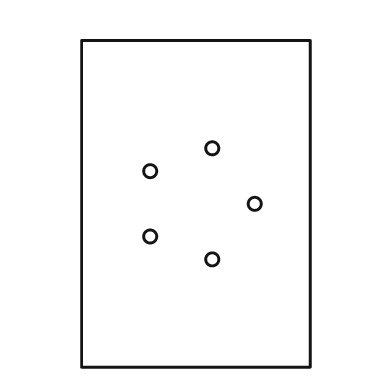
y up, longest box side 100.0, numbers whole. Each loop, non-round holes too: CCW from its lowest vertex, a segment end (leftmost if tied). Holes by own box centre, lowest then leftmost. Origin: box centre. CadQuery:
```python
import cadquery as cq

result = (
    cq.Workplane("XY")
    .moveTo(-35.0, -50.0)
    .lineTo(35.0, -50.0)
    .lineTo(35.0, 50.0)
    .lineTo(-35.0, 50.0)
    .close()
    .moveTo(5.0, -17.0)
    .circle(2.0)
    .moveTo(-14.0, -10.0)
    .circle(2.0)
    .moveTo(18.0, 0.0)
    .circle(2.0)
    .moveTo(-14.0, 10.0)
    .circle(2.0)
    .moveTo(5.0, 17.0)
    .circle(2.0)
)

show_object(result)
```